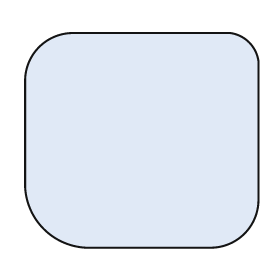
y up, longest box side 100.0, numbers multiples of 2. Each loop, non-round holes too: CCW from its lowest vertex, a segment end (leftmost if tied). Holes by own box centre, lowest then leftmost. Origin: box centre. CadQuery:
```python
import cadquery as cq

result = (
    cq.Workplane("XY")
    .moveTo(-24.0, -46.0)
    .lineTo(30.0, -46.0)
    .threePointArc((44.0, -40.0), (50.0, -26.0))
    .lineTo(50.0, 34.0)
    .threePointArc((46.0, 42.0), (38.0, 46.0))
    .lineTo(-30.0, 46.0)
    .threePointArc((-44.0, 40.0), (-50.0, 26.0))
    .lineTo(-50.0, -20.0)
    .threePointArc((-42.0, -38.0), (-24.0, -46.0))
    .close()
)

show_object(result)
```